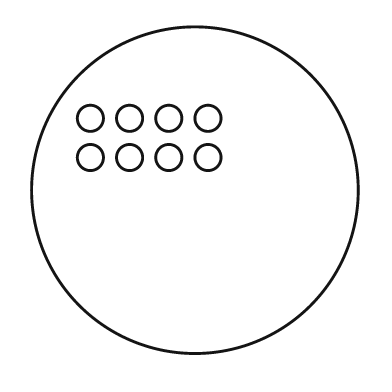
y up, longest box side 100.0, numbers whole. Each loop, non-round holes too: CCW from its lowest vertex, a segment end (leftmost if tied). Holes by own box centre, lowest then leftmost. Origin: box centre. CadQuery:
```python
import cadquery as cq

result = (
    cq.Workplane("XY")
    .moveTo(0.0, 0.0)
    .circle(50.0)
    .moveTo(-32.0, 10.0)
    .circle(4.0)
    .moveTo(-20.0, 10.0)
    .circle(4.0)
    .moveTo(-8.0, 10.0)
    .circle(4.0)
    .moveTo(4.0, 10.0)
    .circle(4.0)
    .moveTo(-32.0, 22.0)
    .circle(4.0)
    .moveTo(-20.0, 22.0)
    .circle(4.0)
    .moveTo(-8.0, 22.0)
    .circle(4.0)
    .moveTo(4.0, 22.0)
    .circle(4.0)
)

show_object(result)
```